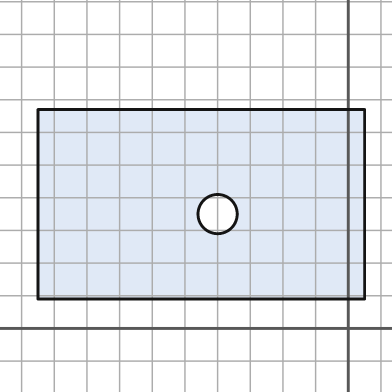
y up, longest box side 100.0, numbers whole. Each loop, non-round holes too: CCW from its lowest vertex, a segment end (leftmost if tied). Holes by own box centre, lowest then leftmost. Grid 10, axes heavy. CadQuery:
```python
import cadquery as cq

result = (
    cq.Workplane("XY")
    .moveTo(-95.0, 9.0)
    .lineTo(5.0, 9.0)
    .lineTo(5.0, 67.0)
    .lineTo(-95.0, 67.0)
    .close()
    .moveTo(-40.0, 35.0)
    .circle(6.0)
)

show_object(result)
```